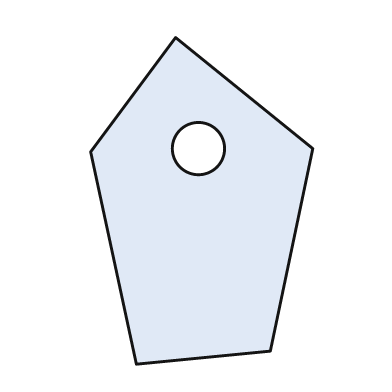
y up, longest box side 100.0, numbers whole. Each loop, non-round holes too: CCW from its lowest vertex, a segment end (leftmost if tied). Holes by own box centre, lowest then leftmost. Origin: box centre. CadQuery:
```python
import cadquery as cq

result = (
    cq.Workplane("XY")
    .moveTo(-20.0, -50.0)
    .lineTo(21.0, -46.0)
    .lineTo(34.0, 16.0)
    .lineTo(-8.0, 50.0)
    .lineTo(-34.0, 15.0)
    .close()
    .moveTo(-1.0, 16.0)
    .circle(8.0)
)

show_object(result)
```